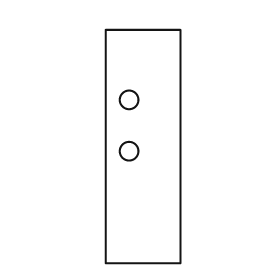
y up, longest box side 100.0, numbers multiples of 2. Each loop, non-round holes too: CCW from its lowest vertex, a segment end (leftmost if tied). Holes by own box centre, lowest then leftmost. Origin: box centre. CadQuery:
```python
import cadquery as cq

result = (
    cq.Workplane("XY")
    .moveTo(-16.0, -50.0)
    .lineTo(16.0, -50.0)
    .lineTo(16.0, 50.0)
    .lineTo(-16.0, 50.0)
    .close()
    .moveTo(-6.0, -2.0)
    .circle(4.0)
    .moveTo(-6.0, 20.0)
    .circle(4.0)
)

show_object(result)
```